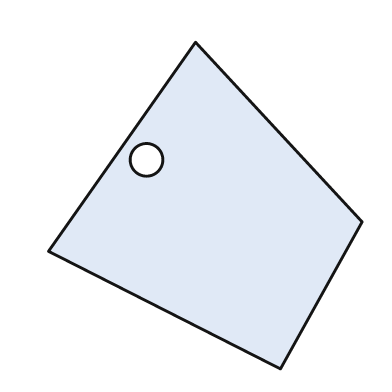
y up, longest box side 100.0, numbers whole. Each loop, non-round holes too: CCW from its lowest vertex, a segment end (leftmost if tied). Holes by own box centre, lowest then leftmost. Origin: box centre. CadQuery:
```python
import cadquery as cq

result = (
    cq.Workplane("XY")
    .moveTo(23.0, -50.0)
    .lineTo(48.0, -5.0)
    .lineTo(-3.0, 50.0)
    .lineTo(-48.0, -14.0)
    .close()
    .moveTo(-18.0, 14.0)
    .circle(5.0)
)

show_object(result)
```